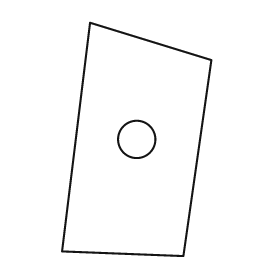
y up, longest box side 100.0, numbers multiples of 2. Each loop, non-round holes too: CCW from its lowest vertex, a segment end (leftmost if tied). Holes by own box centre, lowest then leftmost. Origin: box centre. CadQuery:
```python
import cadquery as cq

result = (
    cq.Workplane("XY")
    .moveTo(20.0, -50.0)
    .lineTo(32.0, 34.0)
    .lineTo(-20.0, 50.0)
    .lineTo(-32.0, -48.0)
    .close()
    .moveTo(0.0, 0.0)
    .circle(8.0)
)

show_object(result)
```